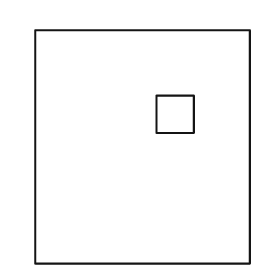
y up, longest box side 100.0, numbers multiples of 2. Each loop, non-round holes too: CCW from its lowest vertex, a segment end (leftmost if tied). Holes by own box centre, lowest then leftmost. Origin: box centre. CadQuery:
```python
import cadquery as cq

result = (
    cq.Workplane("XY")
    .moveTo(-46.0, -50.0)
    .lineTo(46.0, -50.0)
    .lineTo(46.0, 50.0)
    .lineTo(-46.0, 50.0)
    .close()
    .moveTo(6.0, 6.0)
    .lineTo(22.0, 6.0)
    .lineTo(22.0, 22.0)
    .lineTo(6.0, 22.0)
    .close()
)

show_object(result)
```